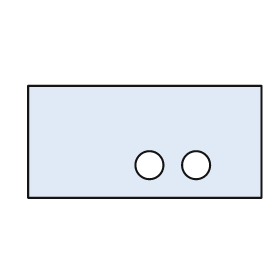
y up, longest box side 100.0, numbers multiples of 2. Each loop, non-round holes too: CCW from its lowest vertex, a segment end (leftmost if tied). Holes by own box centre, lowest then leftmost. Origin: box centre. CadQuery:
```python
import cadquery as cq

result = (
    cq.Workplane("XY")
    .moveTo(-50.0, -24.0)
    .lineTo(50.0, -24.0)
    .lineTo(50.0, 24.0)
    .lineTo(-50.0, 24.0)
    .close()
    .moveTo(2.0, -10.0)
    .circle(6.0)
    .moveTo(22.0, -10.0)
    .circle(6.0)
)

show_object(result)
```